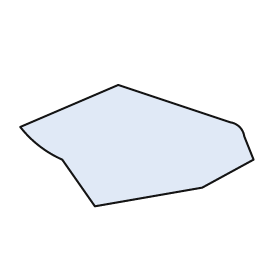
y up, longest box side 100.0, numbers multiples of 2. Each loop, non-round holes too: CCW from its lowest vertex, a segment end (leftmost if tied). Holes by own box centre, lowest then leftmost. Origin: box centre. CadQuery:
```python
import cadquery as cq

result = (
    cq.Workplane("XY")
    .moveTo(-18.0, -26.0)
    .lineTo(28.0, -18.0)
    .lineTo(50.0, -6.0)
    .lineTo(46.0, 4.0)
    .threePointArc((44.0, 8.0), (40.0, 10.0))
    .lineTo(-8.0, 26.0)
    .lineTo(-50.0, 8.0)
    .threePointArc((-42.0, 0.0), (-32.0, -6.0))
    .close()
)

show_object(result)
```